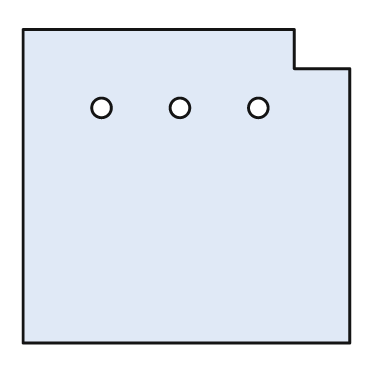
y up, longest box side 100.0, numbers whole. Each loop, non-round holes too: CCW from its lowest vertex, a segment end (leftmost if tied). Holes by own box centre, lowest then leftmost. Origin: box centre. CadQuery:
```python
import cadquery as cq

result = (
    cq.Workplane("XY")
    .moveTo(-50.0, -48.0)
    .lineTo(50.0, -48.0)
    .lineTo(50.0, 36.0)
    .lineTo(33.0, 36.0)
    .lineTo(33.0, 48.0)
    .lineTo(-50.0, 48.0)
    .close()
    .moveTo(-26.0, 24.0)
    .circle(3.0)
    .moveTo(-2.0, 24.0)
    .circle(3.0)
    .moveTo(22.0, 24.0)
    .circle(3.0)
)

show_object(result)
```